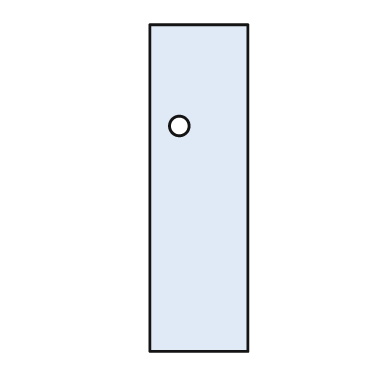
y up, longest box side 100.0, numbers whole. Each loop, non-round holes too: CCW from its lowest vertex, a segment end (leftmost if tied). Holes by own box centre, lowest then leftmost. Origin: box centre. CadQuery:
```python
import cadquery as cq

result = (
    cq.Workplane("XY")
    .moveTo(-15.0, -50.0)
    .lineTo(15.0, -50.0)
    .lineTo(15.0, 50.0)
    .lineTo(-15.0, 50.0)
    .close()
    .moveTo(-6.0, 19.0)
    .circle(3.0)
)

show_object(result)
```